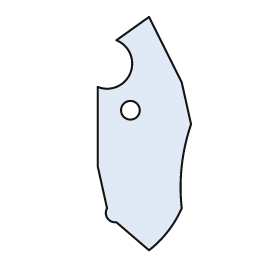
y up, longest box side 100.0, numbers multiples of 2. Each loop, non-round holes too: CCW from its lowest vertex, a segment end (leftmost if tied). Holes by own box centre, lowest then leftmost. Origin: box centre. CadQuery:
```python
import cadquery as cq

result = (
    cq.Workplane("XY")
    .moveTo(2.0, -50.0)
    .threePointArc((10.0, -42.0), (16.0, -32.0))
    .threePointArc((16.0, -14.0), (20.0, 4.0))
    .lineTo(16.0, 22.0)
    .lineTo(2.0, 50.0)
    .lineTo(-12.0, 40.0)
    .threePointArc((-6.0, 26.0), (-20.0, 20.0))
    .lineTo(-20.0, -14.0)
    .lineTo(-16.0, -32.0)
    .threePointArc((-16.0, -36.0), (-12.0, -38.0))
    .close()
    .moveTo(-6.0, 10.0)
    .circle(4.0)
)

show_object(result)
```